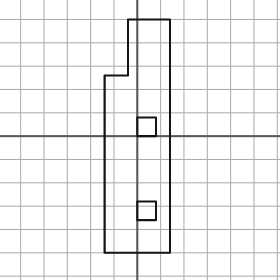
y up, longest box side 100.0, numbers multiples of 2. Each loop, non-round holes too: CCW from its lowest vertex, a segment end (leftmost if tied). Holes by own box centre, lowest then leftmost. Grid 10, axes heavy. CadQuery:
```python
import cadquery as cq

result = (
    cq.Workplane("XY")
    .moveTo(-14.0, -50.0)
    .lineTo(14.0, -50.0)
    .lineTo(14.0, 50.0)
    .lineTo(-4.0, 50.0)
    .lineTo(-4.0, 26.0)
    .lineTo(-14.0, 26.0)
    .close()
    .moveTo(0.0, -36.0)
    .lineTo(8.0, -36.0)
    .lineTo(8.0, -28.0)
    .lineTo(0.0, -28.0)
    .close()
    .moveTo(0.0, 0.0)
    .lineTo(8.0, 0.0)
    .lineTo(8.0, 8.0)
    .lineTo(0.0, 8.0)
    .close()
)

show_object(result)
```